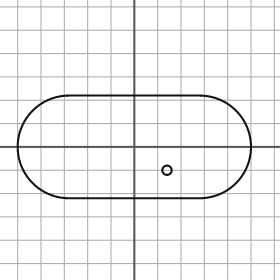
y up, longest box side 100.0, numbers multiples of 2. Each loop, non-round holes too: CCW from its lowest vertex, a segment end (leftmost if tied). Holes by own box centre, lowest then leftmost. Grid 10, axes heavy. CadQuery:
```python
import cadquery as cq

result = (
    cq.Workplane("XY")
    .moveTo(-28.0, -22.0)
    .lineTo(28.0, -22.0)
    .threePointArc((50.0, 0.0), (28.0, 22.0))
    .lineTo(-28.0, 22.0)
    .threePointArc((-50.0, 0.0), (-28.0, -22.0))
    .close()
    .moveTo(14.0, -10.0)
    .circle(2.0)
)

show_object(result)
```